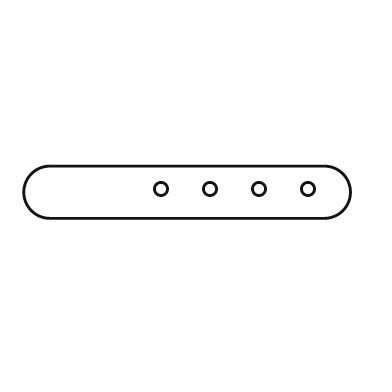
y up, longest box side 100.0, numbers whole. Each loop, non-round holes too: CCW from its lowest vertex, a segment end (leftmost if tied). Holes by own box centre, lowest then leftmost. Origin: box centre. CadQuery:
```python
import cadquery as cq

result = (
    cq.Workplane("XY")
    .moveTo(-42.0, -8.0)
    .lineTo(42.0, -8.0)
    .threePointArc((50.0, 0.0), (42.0, 8.0))
    .lineTo(-42.0, 8.0)
    .threePointArc((-50.0, 0.0), (-42.0, -8.0))
    .close()
    .moveTo(-8.0, 1.0)
    .circle(2.0)
    .moveTo(7.0, 1.0)
    .circle(2.0)
    .moveTo(22.0, 1.0)
    .circle(2.0)
    .moveTo(37.0, 1.0)
    .circle(2.0)
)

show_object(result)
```